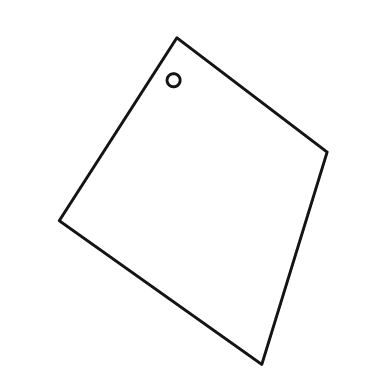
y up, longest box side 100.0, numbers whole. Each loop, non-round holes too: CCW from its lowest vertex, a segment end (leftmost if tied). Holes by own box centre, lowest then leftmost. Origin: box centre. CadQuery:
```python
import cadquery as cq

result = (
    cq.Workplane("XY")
    .moveTo(21.0, -50.0)
    .lineTo(41.0, 15.0)
    .lineTo(-5.0, 50.0)
    .lineTo(-41.0, -6.0)
    .close()
    .moveTo(-6.0, 37.0)
    .circle(2.0)
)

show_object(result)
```